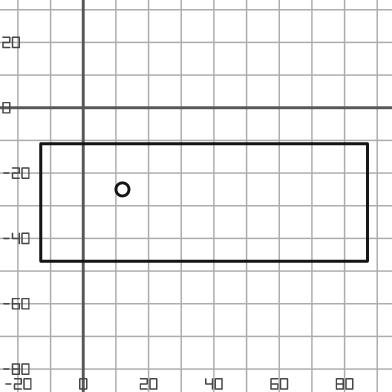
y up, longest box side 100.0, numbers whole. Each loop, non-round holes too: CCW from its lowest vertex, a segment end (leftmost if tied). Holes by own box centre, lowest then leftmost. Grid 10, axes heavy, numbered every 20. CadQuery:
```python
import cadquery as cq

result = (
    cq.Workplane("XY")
    .moveTo(-13.0, -47.0)
    .lineTo(87.0, -47.0)
    .lineTo(87.0, -11.0)
    .lineTo(-13.0, -11.0)
    .close()
    .moveTo(12.0, -25.0)
    .circle(2.0)
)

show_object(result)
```